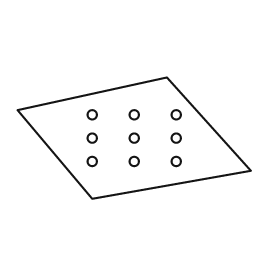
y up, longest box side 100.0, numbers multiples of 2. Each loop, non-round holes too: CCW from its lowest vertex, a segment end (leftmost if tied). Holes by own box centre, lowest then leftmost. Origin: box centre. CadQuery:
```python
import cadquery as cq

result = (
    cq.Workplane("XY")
    .moveTo(-18.0, -26.0)
    .lineTo(50.0, -14.0)
    .lineTo(14.0, 26.0)
    .lineTo(-50.0, 12.0)
    .close()
    .moveTo(-18.0, -10.0)
    .circle(2.0)
    .moveTo(0.0, -10.0)
    .circle(2.0)
    .moveTo(18.0, -10.0)
    .circle(2.0)
    .moveTo(-18.0, 0.0)
    .circle(2.0)
    .moveTo(0.0, 0.0)
    .circle(2.0)
    .moveTo(18.0, 0.0)
    .circle(2.0)
    .moveTo(-18.0, 10.0)
    .circle(2.0)
    .moveTo(0.0, 10.0)
    .circle(2.0)
    .moveTo(18.0, 10.0)
    .circle(2.0)
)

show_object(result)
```